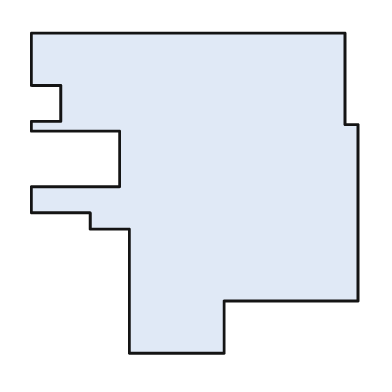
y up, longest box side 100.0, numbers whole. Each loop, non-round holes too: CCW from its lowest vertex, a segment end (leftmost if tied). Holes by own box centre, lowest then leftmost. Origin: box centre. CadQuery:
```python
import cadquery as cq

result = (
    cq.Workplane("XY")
    .moveTo(-20.0, -49.0)
    .lineTo(9.0, -49.0)
    .lineTo(9.0, -33.0)
    .lineTo(50.0, -33.0)
    .lineTo(50.0, 21.0)
    .lineTo(46.0, 21.0)
    .lineTo(46.0, 49.0)
    .lineTo(-50.0, 49.0)
    .lineTo(-50.0, 33.0)
    .lineTo(-41.0, 33.0)
    .lineTo(-41.0, 22.0)
    .lineTo(-50.0, 22.0)
    .lineTo(-50.0, 19.0)
    .lineTo(-23.0, 19.0)
    .lineTo(-23.0, 2.0)
    .lineTo(-50.0, 2.0)
    .lineTo(-50.0, -6.0)
    .lineTo(-32.0, -6.0)
    .lineTo(-32.0, -11.0)
    .lineTo(-20.0, -11.0)
    .close()
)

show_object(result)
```